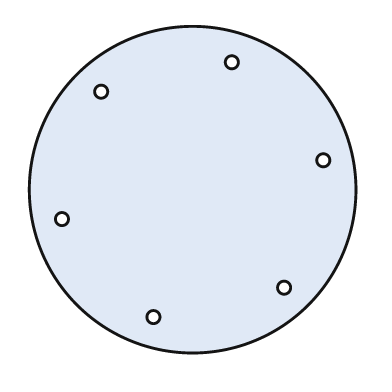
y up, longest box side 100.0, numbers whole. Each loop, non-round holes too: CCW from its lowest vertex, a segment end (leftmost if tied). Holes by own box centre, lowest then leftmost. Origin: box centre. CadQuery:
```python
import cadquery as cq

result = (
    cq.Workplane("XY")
    .moveTo(0.0, 0.0)
    .circle(50.0)
    .moveTo(-12.0, -39.0)
    .circle(2.0)
    .moveTo(28.0, -30.0)
    .circle(2.0)
    .moveTo(-40.0, -9.0)
    .circle(2.0)
    .moveTo(40.0, 9.0)
    .circle(2.0)
    .moveTo(-28.0, 30.0)
    .circle(2.0)
    .moveTo(12.0, 39.0)
    .circle(2.0)
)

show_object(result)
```